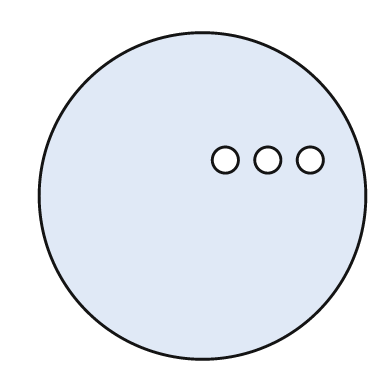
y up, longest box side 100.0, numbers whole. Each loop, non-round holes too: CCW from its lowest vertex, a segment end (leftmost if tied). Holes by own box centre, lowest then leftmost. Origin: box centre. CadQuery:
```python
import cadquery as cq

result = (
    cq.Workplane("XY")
    .moveTo(0.0, 0.0)
    .circle(50.0)
    .moveTo(7.0, 11.0)
    .circle(4.0)
    .moveTo(20.0, 11.0)
    .circle(4.0)
    .moveTo(33.0, 11.0)
    .circle(4.0)
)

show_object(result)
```